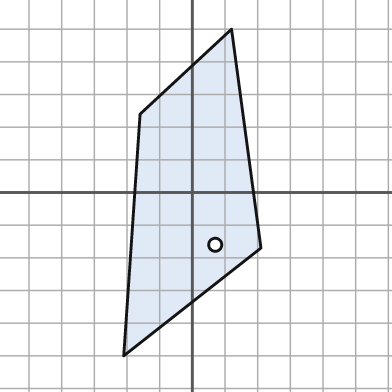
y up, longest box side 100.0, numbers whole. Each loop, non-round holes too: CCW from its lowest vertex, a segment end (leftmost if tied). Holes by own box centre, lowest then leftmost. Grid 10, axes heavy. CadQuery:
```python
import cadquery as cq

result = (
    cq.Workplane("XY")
    .moveTo(-21.0, -50.0)
    .lineTo(21.0, -17.0)
    .lineTo(12.0, 50.0)
    .lineTo(-16.0, 24.0)
    .close()
    .moveTo(7.0, -16.0)
    .circle(2.0)
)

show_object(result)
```